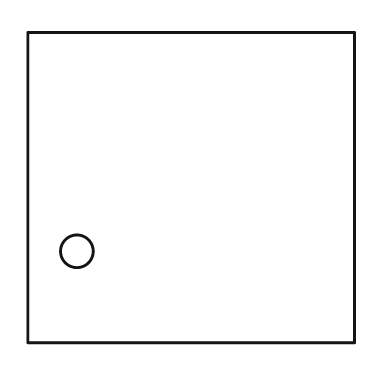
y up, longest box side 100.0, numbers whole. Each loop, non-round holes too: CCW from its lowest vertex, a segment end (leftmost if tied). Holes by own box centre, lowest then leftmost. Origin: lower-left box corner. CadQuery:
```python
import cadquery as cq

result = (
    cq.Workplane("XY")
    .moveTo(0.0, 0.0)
    .lineTo(100.0, 0.0)
    .lineTo(100.0, 95.0)
    .lineTo(0.0, 95.0)
    .close()
    .moveTo(15.0, 28.0)
    .circle(5.0)
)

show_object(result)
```